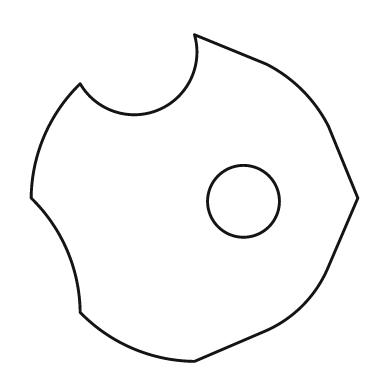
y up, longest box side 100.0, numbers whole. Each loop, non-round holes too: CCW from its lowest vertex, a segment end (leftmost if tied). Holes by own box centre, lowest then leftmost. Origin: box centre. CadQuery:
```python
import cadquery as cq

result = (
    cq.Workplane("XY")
    .moveTo(0.0, -50.0)
    .lineTo(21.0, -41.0)
    .threePointArc((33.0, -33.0), (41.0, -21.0))
    .lineTo(50.0, 0.0)
    .lineTo(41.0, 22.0)
    .threePointArc((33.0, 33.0), (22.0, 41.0))
    .lineTo(0.0, 50.0)
    .threePointArc((-11.0, 27.0), (-35.0, 35.0))
    .threePointArc((-46.0, 19.0), (-50.0, 0.0))
    .threePointArc((-39.0, -16.0), (-35.0, -35.0))
    .threePointArc((-19.0, -46.0), (0.0, -50.0))
    .close()
    .moveTo(15.0, -1.0)
    .circle(11.0)
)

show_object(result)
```